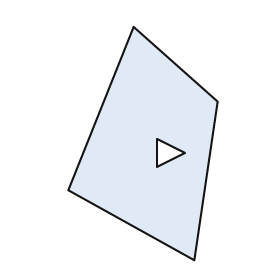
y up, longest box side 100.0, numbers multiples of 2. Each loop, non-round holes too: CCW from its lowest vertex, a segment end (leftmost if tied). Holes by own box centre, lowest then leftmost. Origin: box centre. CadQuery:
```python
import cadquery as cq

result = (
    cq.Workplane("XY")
    .moveTo(22.0, -50.0)
    .lineTo(32.0, 18.0)
    .lineTo(-4.0, 50.0)
    .lineTo(-32.0, -20.0)
    .close()
    .moveTo(6.0, -10.0)
    .lineTo(18.0, -4.0)
    .lineTo(6.0, 2.0)
    .close()
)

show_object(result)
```